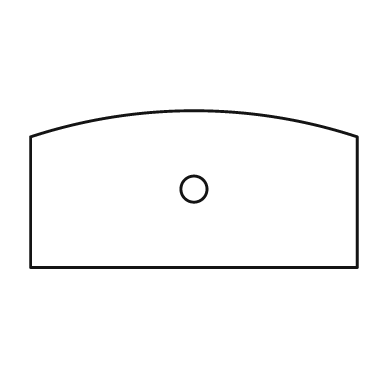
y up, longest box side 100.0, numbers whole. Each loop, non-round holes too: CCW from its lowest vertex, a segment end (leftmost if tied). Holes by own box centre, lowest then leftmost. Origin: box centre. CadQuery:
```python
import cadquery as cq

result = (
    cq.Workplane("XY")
    .moveTo(-50.0, -24.0)
    .lineTo(50.0, -24.0)
    .lineTo(50.0, 16.0)
    .threePointArc((0.0, 24.0), (-50.0, 16.0))
    .close()
    .moveTo(0.0, 0.0)
    .circle(4.0)
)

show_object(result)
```